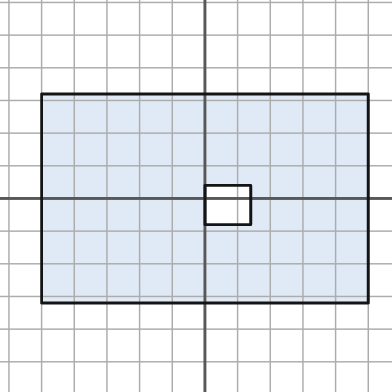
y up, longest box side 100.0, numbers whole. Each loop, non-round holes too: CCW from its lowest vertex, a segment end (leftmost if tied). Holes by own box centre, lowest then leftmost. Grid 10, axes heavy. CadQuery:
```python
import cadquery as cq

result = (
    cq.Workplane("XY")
    .moveTo(-50.0, -32.0)
    .lineTo(50.0, -32.0)
    .lineTo(50.0, 32.0)
    .lineTo(-50.0, 32.0)
    .close()
    .moveTo(0.0, -8.0)
    .lineTo(14.0, -8.0)
    .lineTo(14.0, 4.0)
    .lineTo(0.0, 4.0)
    .close()
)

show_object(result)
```